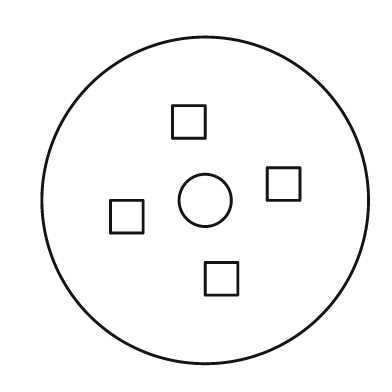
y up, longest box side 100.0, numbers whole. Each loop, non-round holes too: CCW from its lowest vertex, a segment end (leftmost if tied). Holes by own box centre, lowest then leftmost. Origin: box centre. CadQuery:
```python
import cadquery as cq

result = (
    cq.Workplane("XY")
    .moveTo(0.0, 0.0)
    .circle(50.0)
    .moveTo(0.0, -29.0)
    .lineTo(10.0, -29.0)
    .lineTo(10.0, -19.0)
    .lineTo(0.0, -19.0)
    .close()
    .moveTo(-29.0, -10.0)
    .lineTo(-19.0, -10.0)
    .lineTo(-19.0, 0.0)
    .lineTo(-29.0, 0.0)
    .close()
    .moveTo(0.0, 0.0)
    .circle(8.0)
    .moveTo(19.0, 0.0)
    .lineTo(29.0, 0.0)
    .lineTo(29.0, 10.0)
    .lineTo(19.0, 10.0)
    .close()
    .moveTo(-10.0, 19.0)
    .lineTo(0.0, 19.0)
    .lineTo(0.0, 29.0)
    .lineTo(-10.0, 29.0)
    .close()
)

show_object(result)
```